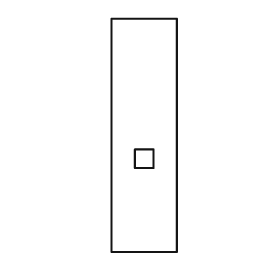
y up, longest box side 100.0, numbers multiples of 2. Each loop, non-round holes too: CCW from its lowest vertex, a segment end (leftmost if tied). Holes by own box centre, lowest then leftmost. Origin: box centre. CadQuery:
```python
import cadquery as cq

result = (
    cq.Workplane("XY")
    .moveTo(-14.0, -50.0)
    .lineTo(14.0, -50.0)
    .lineTo(14.0, 50.0)
    .lineTo(-14.0, 50.0)
    .close()
    .moveTo(-4.0, -14.0)
    .lineTo(4.0, -14.0)
    .lineTo(4.0, -6.0)
    .lineTo(-4.0, -6.0)
    .close()
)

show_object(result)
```